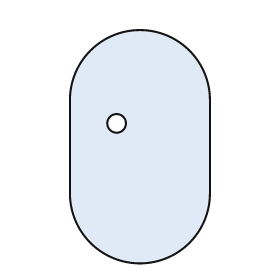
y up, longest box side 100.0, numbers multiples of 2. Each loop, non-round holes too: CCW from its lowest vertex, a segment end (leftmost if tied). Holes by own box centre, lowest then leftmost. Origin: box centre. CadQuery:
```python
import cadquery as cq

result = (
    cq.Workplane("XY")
    .moveTo(-30.0, -20.0)
    .threePointArc((0.0, -50.0), (30.0, -20.0))
    .lineTo(30.0, 20.0)
    .threePointArc((0.0, 50.0), (-30.0, 20.0))
    .close()
    .moveTo(-10.0, 10.0)
    .circle(4.0)
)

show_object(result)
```